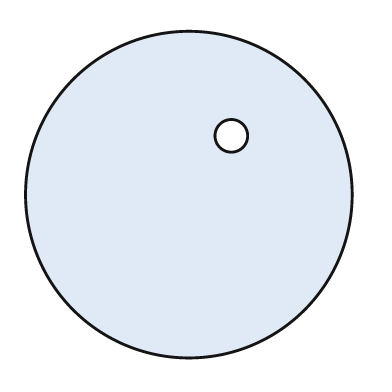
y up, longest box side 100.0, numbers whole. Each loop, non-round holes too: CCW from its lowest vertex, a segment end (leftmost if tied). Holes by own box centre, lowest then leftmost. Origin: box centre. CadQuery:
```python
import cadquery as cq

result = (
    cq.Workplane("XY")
    .moveTo(0.0, 0.0)
    .circle(50.0)
    .moveTo(13.0, 18.0)
    .circle(5.0)
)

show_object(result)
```